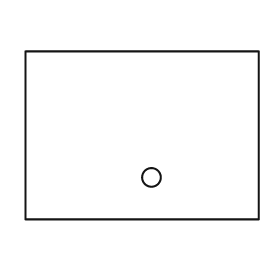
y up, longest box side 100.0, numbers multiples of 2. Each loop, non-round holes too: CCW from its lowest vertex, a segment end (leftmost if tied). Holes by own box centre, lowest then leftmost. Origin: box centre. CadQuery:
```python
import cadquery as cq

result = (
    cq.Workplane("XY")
    .moveTo(-50.0, -36.0)
    .lineTo(50.0, -36.0)
    .lineTo(50.0, 36.0)
    .lineTo(-50.0, 36.0)
    .close()
    .moveTo(4.0, -18.0)
    .circle(4.0)
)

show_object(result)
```